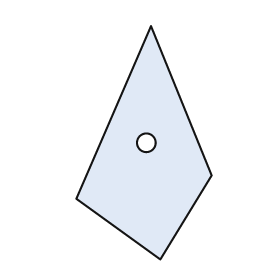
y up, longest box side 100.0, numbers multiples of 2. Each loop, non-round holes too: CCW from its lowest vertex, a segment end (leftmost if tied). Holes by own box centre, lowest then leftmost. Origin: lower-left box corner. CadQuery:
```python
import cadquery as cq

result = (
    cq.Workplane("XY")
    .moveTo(36.0, 0.0)
    .lineTo(58.0, 36.0)
    .lineTo(32.0, 100.0)
    .lineTo(0.0, 26.0)
    .close()
    .moveTo(30.0, 50.0)
    .circle(4.0)
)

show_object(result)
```